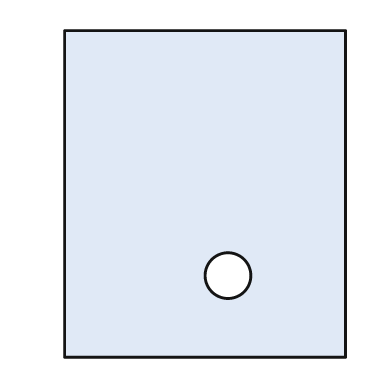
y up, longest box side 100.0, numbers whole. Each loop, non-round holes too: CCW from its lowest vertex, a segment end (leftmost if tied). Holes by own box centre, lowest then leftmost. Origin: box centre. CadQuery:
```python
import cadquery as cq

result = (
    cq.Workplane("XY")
    .moveTo(-43.0, -50.0)
    .lineTo(43.0, -50.0)
    .lineTo(43.0, 50.0)
    .lineTo(-43.0, 50.0)
    .close()
    .moveTo(7.0, -25.0)
    .circle(7.0)
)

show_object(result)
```